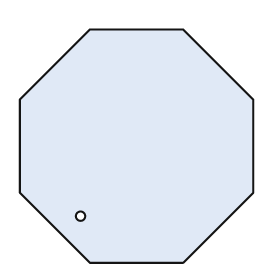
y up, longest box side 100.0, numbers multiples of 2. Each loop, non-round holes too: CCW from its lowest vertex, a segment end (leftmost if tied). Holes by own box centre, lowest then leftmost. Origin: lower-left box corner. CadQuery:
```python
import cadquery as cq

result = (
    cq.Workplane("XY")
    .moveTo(30.0, 0.0)
    .lineTo(70.0, 0.0)
    .lineTo(100.0, 30.0)
    .lineTo(100.0, 70.0)
    .lineTo(70.0, 100.0)
    .lineTo(30.0, 100.0)
    .lineTo(0.0, 70.0)
    .lineTo(0.0, 30.0)
    .close()
    .moveTo(26.0, 20.0)
    .circle(2.0)
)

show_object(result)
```